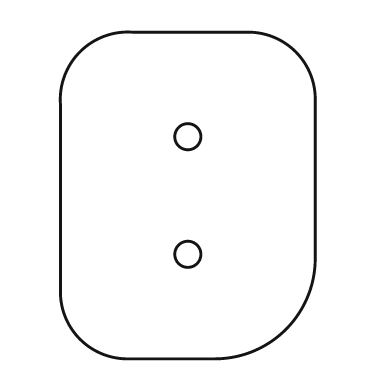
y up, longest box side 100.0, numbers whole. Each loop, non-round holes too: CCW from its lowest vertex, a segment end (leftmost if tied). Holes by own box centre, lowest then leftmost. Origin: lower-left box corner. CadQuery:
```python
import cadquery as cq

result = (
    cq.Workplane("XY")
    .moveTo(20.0, 0.0)
    .lineTo(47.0, 0.0)
    .threePointArc((69.0, 9.0), (78.0, 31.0))
    .lineTo(78.0, 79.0)
    .threePointArc((72.0, 94.0), (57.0, 100.0))
    .lineTo(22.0, 100.0)
    .threePointArc((6.0, 94.0), (0.0, 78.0))
    .lineTo(0.0, 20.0)
    .threePointArc((6.0, 6.0), (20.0, 0.0))
    .close()
    .moveTo(39.0, 32.0)
    .circle(4.0)
    .moveTo(39.0, 68.0)
    .circle(4.0)
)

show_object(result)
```